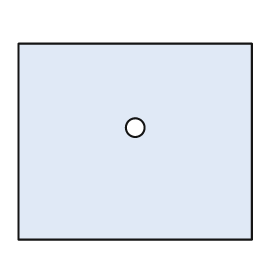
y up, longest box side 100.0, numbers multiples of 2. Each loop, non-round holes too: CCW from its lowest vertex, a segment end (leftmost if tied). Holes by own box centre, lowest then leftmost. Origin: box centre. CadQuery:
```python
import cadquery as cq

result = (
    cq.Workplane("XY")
    .moveTo(-50.0, -42.0)
    .lineTo(50.0, -42.0)
    .lineTo(50.0, 42.0)
    .lineTo(-50.0, 42.0)
    .close()
    .moveTo(0.0, 6.0)
    .circle(4.0)
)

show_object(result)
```